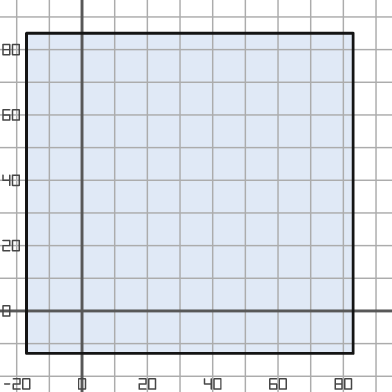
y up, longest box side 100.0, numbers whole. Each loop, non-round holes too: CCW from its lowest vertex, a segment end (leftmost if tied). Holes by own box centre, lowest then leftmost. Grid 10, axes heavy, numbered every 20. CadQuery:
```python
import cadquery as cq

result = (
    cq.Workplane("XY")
    .moveTo(-17.0, -13.0)
    .lineTo(83.0, -13.0)
    .lineTo(83.0, 85.0)
    .lineTo(-17.0, 85.0)
    .close()
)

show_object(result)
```